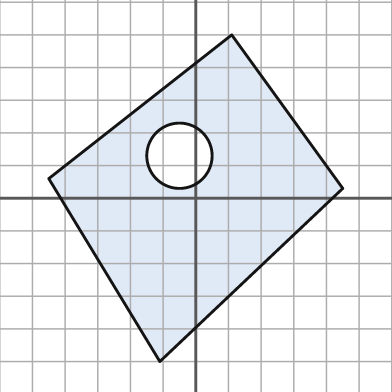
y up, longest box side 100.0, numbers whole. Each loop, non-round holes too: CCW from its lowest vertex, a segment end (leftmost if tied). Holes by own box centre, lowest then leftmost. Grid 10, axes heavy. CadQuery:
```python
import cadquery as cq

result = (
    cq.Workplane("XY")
    .moveTo(-11.0, -50.0)
    .lineTo(45.0, 3.0)
    .lineTo(11.0, 50.0)
    .lineTo(-45.0, 6.0)
    .close()
    .moveTo(-5.0, 13.0)
    .circle(10.0)
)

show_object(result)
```